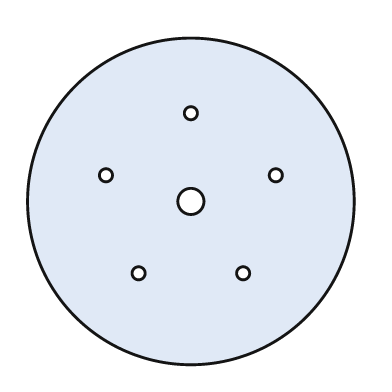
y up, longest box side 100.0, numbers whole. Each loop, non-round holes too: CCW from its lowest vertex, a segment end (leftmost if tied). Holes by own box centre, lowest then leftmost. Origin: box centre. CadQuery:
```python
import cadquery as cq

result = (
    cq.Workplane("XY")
    .moveTo(0.0, 0.0)
    .circle(50.0)
    .moveTo(-16.0, -22.0)
    .circle(2.0)
    .moveTo(16.0, -22.0)
    .circle(2.0)
    .moveTo(0.0, 0.0)
    .circle(4.0)
    .moveTo(-26.0, 8.0)
    .circle(2.0)
    .moveTo(26.0, 8.0)
    .circle(2.0)
    .moveTo(0.0, 27.0)
    .circle(2.0)
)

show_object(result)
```